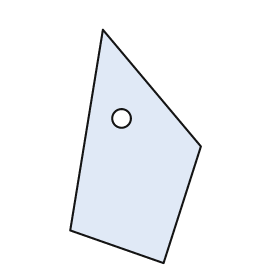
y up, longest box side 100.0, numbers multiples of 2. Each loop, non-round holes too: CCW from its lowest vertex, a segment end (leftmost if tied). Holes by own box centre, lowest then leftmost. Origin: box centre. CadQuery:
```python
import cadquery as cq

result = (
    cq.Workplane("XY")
    .moveTo(12.0, -50.0)
    .lineTo(28.0, 0.0)
    .lineTo(-14.0, 50.0)
    .lineTo(-28.0, -36.0)
    .close()
    .moveTo(-6.0, 12.0)
    .circle(4.0)
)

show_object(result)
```